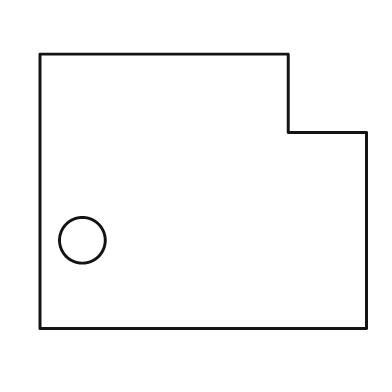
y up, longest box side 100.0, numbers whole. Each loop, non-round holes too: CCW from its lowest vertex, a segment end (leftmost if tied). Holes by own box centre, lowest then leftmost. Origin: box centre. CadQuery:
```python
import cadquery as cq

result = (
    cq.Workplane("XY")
    .moveTo(-50.0, -42.0)
    .lineTo(50.0, -42.0)
    .lineTo(50.0, 18.0)
    .lineTo(26.0, 18.0)
    .lineTo(26.0, 42.0)
    .lineTo(-50.0, 42.0)
    .close()
    .moveTo(-37.0, -15.0)
    .circle(7.0)
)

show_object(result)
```